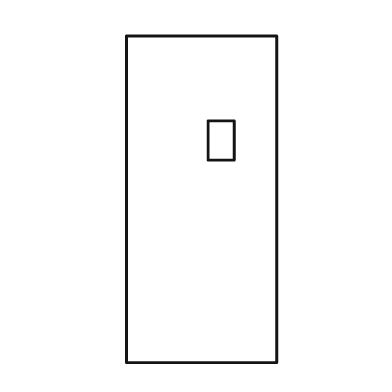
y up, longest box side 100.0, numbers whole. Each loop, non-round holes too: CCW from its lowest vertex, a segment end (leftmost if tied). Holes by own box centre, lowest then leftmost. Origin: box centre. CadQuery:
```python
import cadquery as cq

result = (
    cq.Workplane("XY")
    .moveTo(-23.0, -50.0)
    .lineTo(23.0, -50.0)
    .lineTo(23.0, 50.0)
    .lineTo(-23.0, 50.0)
    .close()
    .moveTo(2.0, 12.0)
    .lineTo(10.0, 12.0)
    .lineTo(10.0, 24.0)
    .lineTo(2.0, 24.0)
    .close()
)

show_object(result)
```